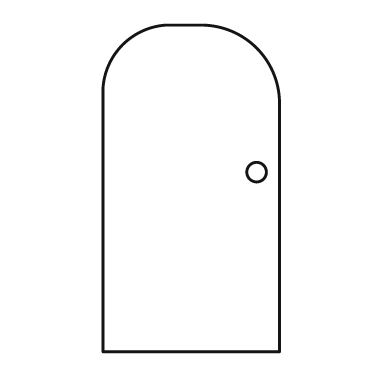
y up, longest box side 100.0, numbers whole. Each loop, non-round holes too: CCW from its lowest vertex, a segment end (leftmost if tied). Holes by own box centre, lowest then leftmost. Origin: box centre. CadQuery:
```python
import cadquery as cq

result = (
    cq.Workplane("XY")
    .moveTo(-27.0, -50.0)
    .lineTo(27.0, -50.0)
    .lineTo(27.0, 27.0)
    .threePointArc((20.0, 43.0), (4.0, 50.0))
    .lineTo(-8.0, 50.0)
    .threePointArc((-21.0, 44.0), (-27.0, 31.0))
    .close()
    .moveTo(20.0, 5.0)
    .circle(3.0)
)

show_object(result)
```